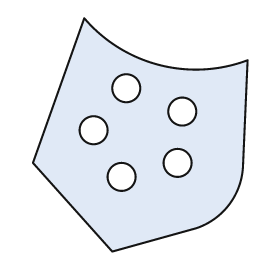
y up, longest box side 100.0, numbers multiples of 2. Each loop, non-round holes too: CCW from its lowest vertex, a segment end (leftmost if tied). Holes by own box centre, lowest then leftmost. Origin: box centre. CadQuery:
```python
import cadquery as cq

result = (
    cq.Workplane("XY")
    .moveTo(-12.0, -50.0)
    .lineTo(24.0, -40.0)
    .threePointArc((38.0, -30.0), (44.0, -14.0))
    .lineTo(46.0, 32.0)
    .threePointArc((8.0, 30.0), (-24.0, 50.0))
    .lineTo(-46.0, -12.0)
    .close()
    .moveTo(-8.0, -18.0)
    .circle(6.0)
    .moveTo(16.0, -12.0)
    .circle(6.0)
    .moveTo(-20.0, 2.0)
    .circle(6.0)
    .moveTo(18.0, 10.0)
    .circle(6.0)
    .moveTo(-6.0, 20.0)
    .circle(6.0)
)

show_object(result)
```